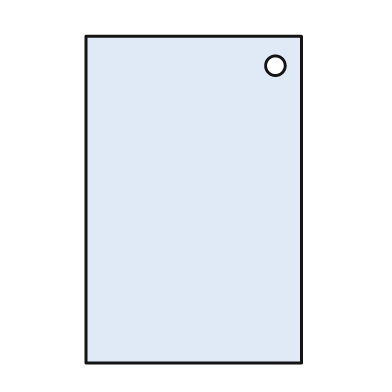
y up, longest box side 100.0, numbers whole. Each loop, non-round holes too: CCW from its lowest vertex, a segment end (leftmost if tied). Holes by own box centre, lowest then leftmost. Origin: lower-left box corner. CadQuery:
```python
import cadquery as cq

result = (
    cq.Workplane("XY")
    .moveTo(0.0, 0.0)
    .lineTo(66.0, 0.0)
    .lineTo(66.0, 100.0)
    .lineTo(0.0, 100.0)
    .close()
    .moveTo(58.0, 91.0)
    .circle(3.0)
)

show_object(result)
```